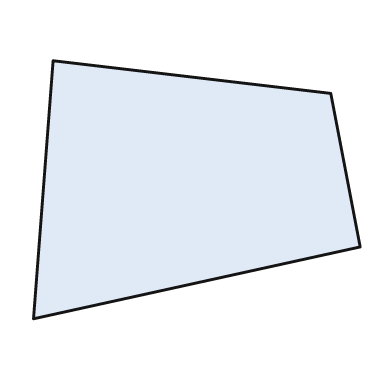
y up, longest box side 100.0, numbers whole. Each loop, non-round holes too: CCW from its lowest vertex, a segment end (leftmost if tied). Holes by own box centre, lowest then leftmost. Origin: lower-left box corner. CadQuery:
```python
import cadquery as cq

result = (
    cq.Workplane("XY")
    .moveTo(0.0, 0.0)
    .lineTo(100.0, 22.0)
    .lineTo(91.0, 69.0)
    .lineTo(6.0, 79.0)
    .close()
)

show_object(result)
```